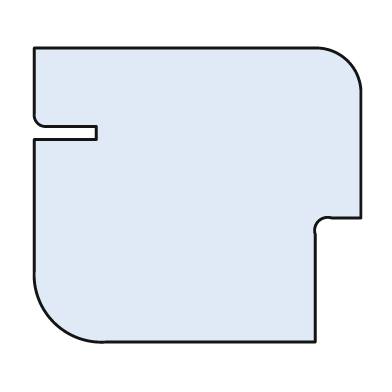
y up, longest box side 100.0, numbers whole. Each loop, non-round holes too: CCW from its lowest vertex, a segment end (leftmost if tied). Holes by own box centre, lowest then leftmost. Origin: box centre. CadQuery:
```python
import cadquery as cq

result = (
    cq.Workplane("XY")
    .moveTo(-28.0, -45.0)
    .lineTo(36.0, -45.0)
    .lineTo(36.0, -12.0)
    .threePointArc((37.0, -8.0), (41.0, -7.0))
    .lineTo(50.0, -7.0)
    .lineTo(50.0, 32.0)
    .threePointArc((46.0, 41.0), (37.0, 45.0))
    .lineTo(-50.0, 45.0)
    .lineTo(-50.0, 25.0)
    .threePointArc((-49.0, 22.0), (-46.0, 21.0))
    .lineTo(-31.0, 21.0)
    .lineTo(-31.0, 17.0)
    .lineTo(-50.0, 17.0)
    .lineTo(-50.0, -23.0)
    .threePointArc((-44.0, -39.0), (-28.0, -45.0))
    .close()
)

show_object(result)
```